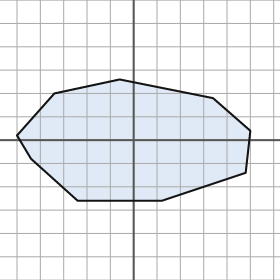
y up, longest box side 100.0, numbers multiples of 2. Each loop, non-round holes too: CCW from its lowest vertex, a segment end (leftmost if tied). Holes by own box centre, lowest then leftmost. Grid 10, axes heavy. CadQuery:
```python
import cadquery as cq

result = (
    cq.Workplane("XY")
    .moveTo(-24.0, -26.0)
    .lineTo(12.0, -26.0)
    .lineTo(48.0, -14.0)
    .lineTo(50.0, 4.0)
    .lineTo(34.0, 18.0)
    .lineTo(-6.0, 26.0)
    .lineTo(-34.0, 20.0)
    .lineTo(-50.0, 2.0)
    .lineTo(-44.0, -8.0)
    .close()
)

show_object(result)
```